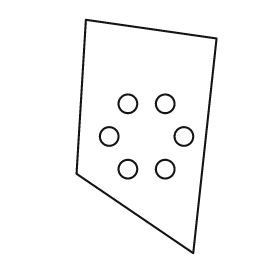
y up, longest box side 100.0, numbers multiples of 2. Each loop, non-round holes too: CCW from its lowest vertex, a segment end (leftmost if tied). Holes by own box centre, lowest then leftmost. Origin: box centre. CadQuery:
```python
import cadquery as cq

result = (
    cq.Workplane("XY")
    .moveTo(20.0, -50.0)
    .lineTo(30.0, 42.0)
    .lineTo(-26.0, 50.0)
    .lineTo(-30.0, -16.0)
    .close()
    .moveTo(-8.0, -14.0)
    .circle(4.0)
    .moveTo(8.0, -14.0)
    .circle(4.0)
    .moveTo(-16.0, 0.0)
    .circle(4.0)
    .moveTo(16.0, 0.0)
    .circle(4.0)
    .moveTo(-8.0, 14.0)
    .circle(4.0)
    .moveTo(8.0, 14.0)
    .circle(4.0)
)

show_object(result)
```